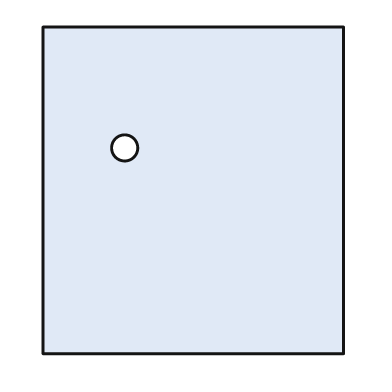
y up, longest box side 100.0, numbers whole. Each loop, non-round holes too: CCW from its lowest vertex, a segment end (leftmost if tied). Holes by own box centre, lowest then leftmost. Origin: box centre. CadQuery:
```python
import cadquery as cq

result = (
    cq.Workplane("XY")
    .moveTo(-46.0, -50.0)
    .lineTo(46.0, -50.0)
    .lineTo(46.0, 50.0)
    .lineTo(-46.0, 50.0)
    .close()
    .moveTo(-21.0, 13.0)
    .circle(4.0)
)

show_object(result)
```